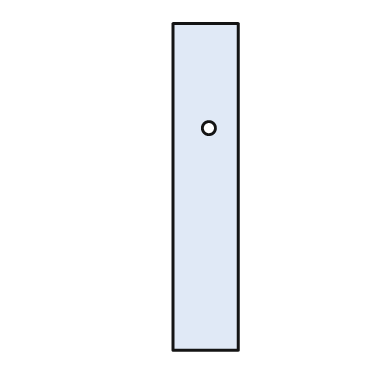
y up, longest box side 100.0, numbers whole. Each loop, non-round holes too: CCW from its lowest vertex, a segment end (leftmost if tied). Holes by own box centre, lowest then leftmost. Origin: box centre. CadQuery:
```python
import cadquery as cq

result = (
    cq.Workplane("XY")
    .moveTo(-10.0, -50.0)
    .lineTo(10.0, -50.0)
    .lineTo(10.0, 50.0)
    .lineTo(-10.0, 50.0)
    .close()
    .moveTo(1.0, 18.0)
    .circle(2.0)
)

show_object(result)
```